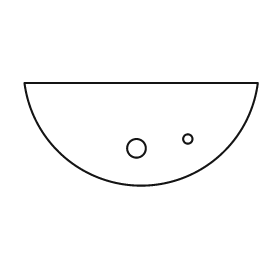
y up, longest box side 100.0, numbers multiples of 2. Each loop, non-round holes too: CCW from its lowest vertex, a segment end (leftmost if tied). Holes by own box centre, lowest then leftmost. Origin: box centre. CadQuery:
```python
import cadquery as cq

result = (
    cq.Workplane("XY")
    .moveTo(-50.0, 22.0)
    .threePointArc((0.0, -22.0), (50.0, 22.0))
    .close()
    .moveTo(-2.0, -6.0)
    .circle(4.0)
    .moveTo(20.0, -2.0)
    .circle(2.0)
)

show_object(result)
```